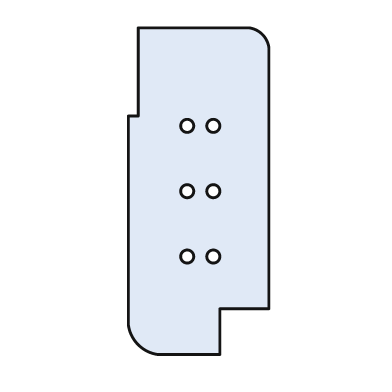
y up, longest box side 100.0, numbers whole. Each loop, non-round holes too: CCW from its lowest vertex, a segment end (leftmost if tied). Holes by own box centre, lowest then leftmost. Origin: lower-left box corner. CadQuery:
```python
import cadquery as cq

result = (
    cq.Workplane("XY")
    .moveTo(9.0, 0.0)
    .lineTo(28.0, 0.0)
    .lineTo(28.0, 14.0)
    .lineTo(43.0, 14.0)
    .lineTo(43.0, 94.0)
    .threePointArc((41.0, 98.0), (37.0, 100.0))
    .lineTo(3.0, 100.0)
    .lineTo(3.0, 73.0)
    .lineTo(0.0, 73.0)
    .lineTo(0.0, 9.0)
    .threePointArc((3.0, 3.0), (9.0, 0.0))
    .close()
    .moveTo(18.0, 30.0)
    .circle(2.0)
    .moveTo(26.0, 30.0)
    .circle(2.0)
    .moveTo(18.0, 50.0)
    .circle(2.0)
    .moveTo(26.0, 50.0)
    .circle(2.0)
    .moveTo(18.0, 70.0)
    .circle(2.0)
    .moveTo(26.0, 70.0)
    .circle(2.0)
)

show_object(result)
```